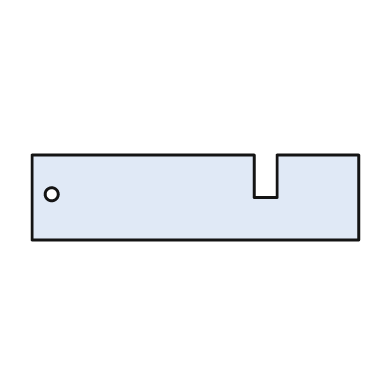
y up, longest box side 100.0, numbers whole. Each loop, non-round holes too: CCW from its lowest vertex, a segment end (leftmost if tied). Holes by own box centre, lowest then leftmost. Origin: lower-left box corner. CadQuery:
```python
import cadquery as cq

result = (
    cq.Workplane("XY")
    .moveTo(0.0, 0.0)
    .lineTo(100.0, 0.0)
    .lineTo(100.0, 26.0)
    .lineTo(75.0, 26.0)
    .lineTo(75.0, 13.0)
    .lineTo(68.0, 13.0)
    .lineTo(68.0, 26.0)
    .lineTo(0.0, 26.0)
    .close()
    .moveTo(6.0, 14.0)
    .circle(2.0)
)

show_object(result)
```